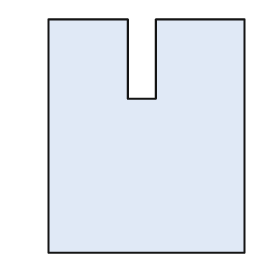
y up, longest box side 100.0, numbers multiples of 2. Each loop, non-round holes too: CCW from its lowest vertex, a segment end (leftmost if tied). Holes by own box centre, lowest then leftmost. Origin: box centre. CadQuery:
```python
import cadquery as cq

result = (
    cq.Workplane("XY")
    .moveTo(-42.0, -50.0)
    .lineTo(42.0, -50.0)
    .lineTo(42.0, 50.0)
    .lineTo(4.0, 50.0)
    .lineTo(4.0, 16.0)
    .lineTo(-8.0, 16.0)
    .lineTo(-8.0, 50.0)
    .lineTo(-42.0, 50.0)
    .close()
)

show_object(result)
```